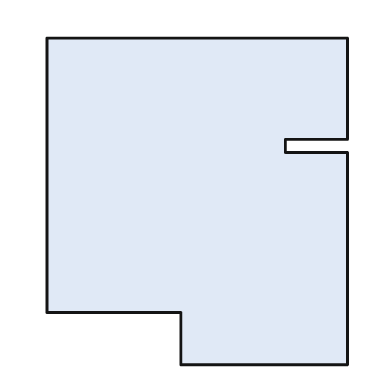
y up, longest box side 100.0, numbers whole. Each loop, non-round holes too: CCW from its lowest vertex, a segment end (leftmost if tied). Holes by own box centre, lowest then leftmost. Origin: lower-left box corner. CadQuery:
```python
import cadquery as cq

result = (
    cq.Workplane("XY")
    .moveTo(41.0, 0.0)
    .lineTo(92.0, 0.0)
    .lineTo(92.0, 65.0)
    .lineTo(73.0, 65.0)
    .lineTo(73.0, 69.0)
    .lineTo(92.0, 69.0)
    .lineTo(92.0, 100.0)
    .lineTo(0.0, 100.0)
    .lineTo(0.0, 16.0)
    .lineTo(41.0, 16.0)
    .close()
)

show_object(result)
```